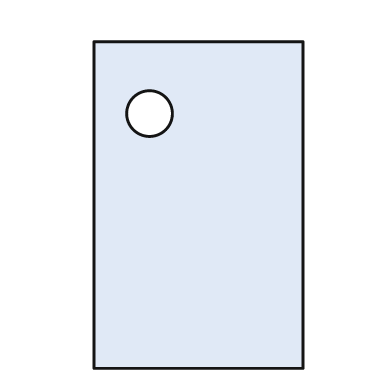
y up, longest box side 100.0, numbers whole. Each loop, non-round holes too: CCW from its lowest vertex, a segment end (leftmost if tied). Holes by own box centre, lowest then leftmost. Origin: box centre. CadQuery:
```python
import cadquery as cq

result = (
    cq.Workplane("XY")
    .moveTo(-32.0, -50.0)
    .lineTo(32.0, -50.0)
    .lineTo(32.0, 50.0)
    .lineTo(-32.0, 50.0)
    .close()
    .moveTo(-15.0, 28.0)
    .circle(7.0)
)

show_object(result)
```